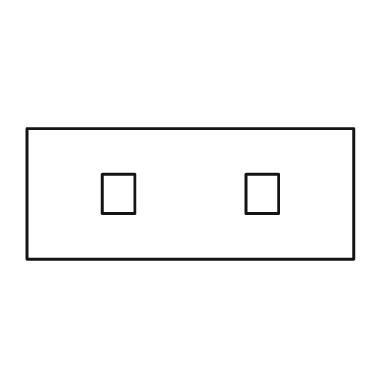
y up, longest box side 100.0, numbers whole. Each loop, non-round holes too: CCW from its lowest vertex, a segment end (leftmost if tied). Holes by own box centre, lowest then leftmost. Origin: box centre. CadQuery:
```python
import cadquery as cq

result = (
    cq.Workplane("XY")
    .moveTo(-50.0, -20.0)
    .lineTo(50.0, -20.0)
    .lineTo(50.0, 20.0)
    .lineTo(-50.0, 20.0)
    .close()
    .moveTo(-27.0, -6.0)
    .lineTo(-17.0, -6.0)
    .lineTo(-17.0, 6.0)
    .lineTo(-27.0, 6.0)
    .close()
    .moveTo(17.0, -6.0)
    .lineTo(27.0, -6.0)
    .lineTo(27.0, 6.0)
    .lineTo(17.0, 6.0)
    .close()
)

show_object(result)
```